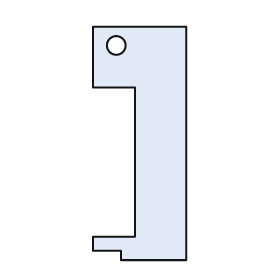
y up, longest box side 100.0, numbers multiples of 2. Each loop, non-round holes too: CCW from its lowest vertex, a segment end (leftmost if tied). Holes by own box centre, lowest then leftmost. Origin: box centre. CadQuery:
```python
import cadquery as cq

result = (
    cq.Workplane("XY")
    .moveTo(-8.0, -50.0)
    .lineTo(20.0, -50.0)
    .lineTo(20.0, 50.0)
    .lineTo(-20.0, 50.0)
    .lineTo(-20.0, 24.0)
    .lineTo(-2.0, 24.0)
    .lineTo(-2.0, -40.0)
    .lineTo(-20.0, -40.0)
    .lineTo(-20.0, -46.0)
    .lineTo(-8.0, -46.0)
    .close()
    .moveTo(-10.0, 42.0)
    .circle(4.0)
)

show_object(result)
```